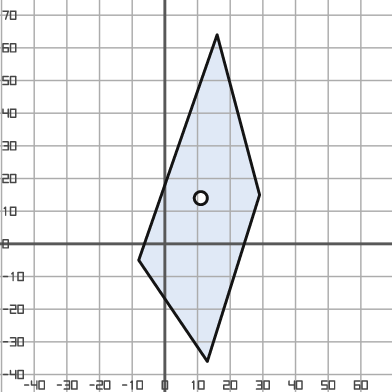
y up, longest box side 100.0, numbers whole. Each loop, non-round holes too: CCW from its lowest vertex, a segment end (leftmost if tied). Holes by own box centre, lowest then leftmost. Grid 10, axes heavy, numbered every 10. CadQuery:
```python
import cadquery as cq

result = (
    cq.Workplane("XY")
    .moveTo(13.0, -36.0)
    .lineTo(29.0, 15.0)
    .lineTo(16.0, 64.0)
    .lineTo(-8.0, -5.0)
    .close()
    .moveTo(11.0, 14.0)
    .circle(2.0)
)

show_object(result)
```